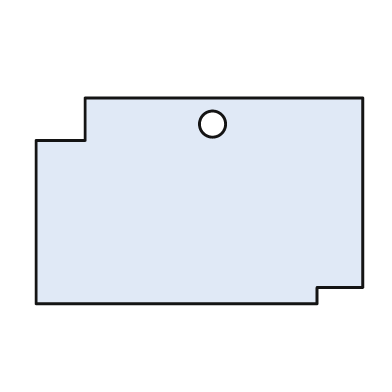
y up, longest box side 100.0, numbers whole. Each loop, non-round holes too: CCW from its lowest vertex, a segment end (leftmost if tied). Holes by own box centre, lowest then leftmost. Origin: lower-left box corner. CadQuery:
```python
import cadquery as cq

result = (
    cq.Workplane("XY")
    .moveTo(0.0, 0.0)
    .lineTo(86.0, 0.0)
    .lineTo(86.0, 5.0)
    .lineTo(100.0, 5.0)
    .lineTo(100.0, 63.0)
    .lineTo(15.0, 63.0)
    .lineTo(15.0, 50.0)
    .lineTo(0.0, 50.0)
    .close()
    .moveTo(54.0, 55.0)
    .circle(4.0)
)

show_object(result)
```